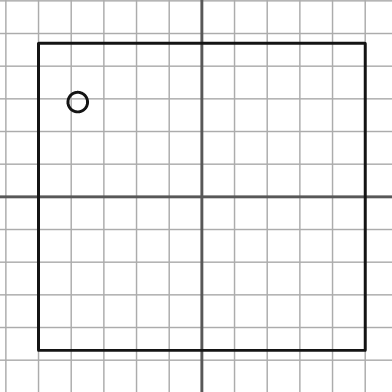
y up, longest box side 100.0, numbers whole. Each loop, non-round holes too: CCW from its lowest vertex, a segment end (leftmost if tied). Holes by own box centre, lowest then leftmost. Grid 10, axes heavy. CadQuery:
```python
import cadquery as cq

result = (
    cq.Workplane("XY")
    .moveTo(-50.0, -47.0)
    .lineTo(50.0, -47.0)
    .lineTo(50.0, 47.0)
    .lineTo(-50.0, 47.0)
    .close()
    .moveTo(-38.0, 29.0)
    .circle(3.0)
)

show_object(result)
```